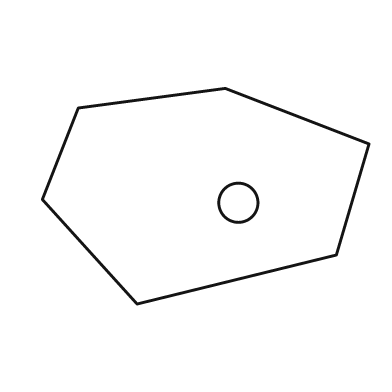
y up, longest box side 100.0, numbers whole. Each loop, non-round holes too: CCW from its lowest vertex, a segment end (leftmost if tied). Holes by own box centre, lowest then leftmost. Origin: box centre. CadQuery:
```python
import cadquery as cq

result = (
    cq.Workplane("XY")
    .moveTo(-21.0, -33.0)
    .lineTo(40.0, -18.0)
    .lineTo(50.0, 16.0)
    .lineTo(6.0, 33.0)
    .lineTo(-39.0, 27.0)
    .lineTo(-50.0, -1.0)
    .close()
    .moveTo(10.0, -2.0)
    .circle(6.0)
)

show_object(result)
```